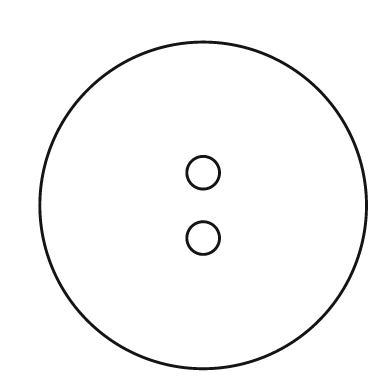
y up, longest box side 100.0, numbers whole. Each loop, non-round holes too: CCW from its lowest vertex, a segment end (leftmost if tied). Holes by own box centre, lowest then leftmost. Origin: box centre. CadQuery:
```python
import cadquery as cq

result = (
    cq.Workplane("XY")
    .moveTo(0.0, 0.0)
    .circle(50.0)
    .moveTo(0.0, -10.0)
    .circle(5.0)
    .moveTo(0.0, 10.0)
    .circle(5.0)
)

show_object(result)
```